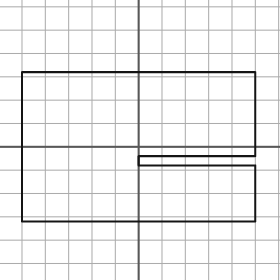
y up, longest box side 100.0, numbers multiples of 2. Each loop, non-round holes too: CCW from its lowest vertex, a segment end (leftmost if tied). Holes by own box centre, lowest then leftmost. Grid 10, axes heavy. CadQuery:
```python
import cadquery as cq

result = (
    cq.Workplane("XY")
    .moveTo(-50.0, -32.0)
    .lineTo(50.0, -32.0)
    .lineTo(50.0, -8.0)
    .lineTo(0.0, -8.0)
    .lineTo(0.0, -4.0)
    .lineTo(50.0, -4.0)
    .lineTo(50.0, 32.0)
    .lineTo(-50.0, 32.0)
    .close()
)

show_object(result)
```